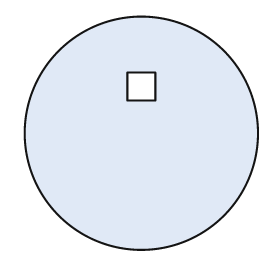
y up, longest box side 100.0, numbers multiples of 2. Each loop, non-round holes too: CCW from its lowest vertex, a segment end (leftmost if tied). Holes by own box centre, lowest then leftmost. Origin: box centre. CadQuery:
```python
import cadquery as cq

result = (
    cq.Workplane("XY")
    .moveTo(0.0, 0.0)
    .circle(50.0)
    .moveTo(-6.0, 14.0)
    .lineTo(6.0, 14.0)
    .lineTo(6.0, 26.0)
    .lineTo(-6.0, 26.0)
    .close()
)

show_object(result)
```